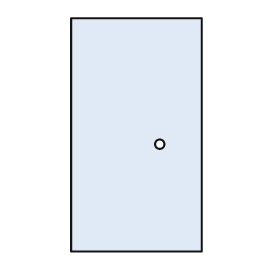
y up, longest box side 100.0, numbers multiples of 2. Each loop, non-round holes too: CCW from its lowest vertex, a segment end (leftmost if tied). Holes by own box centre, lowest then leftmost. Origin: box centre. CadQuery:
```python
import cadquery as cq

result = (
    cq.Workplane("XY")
    .moveTo(-28.0, -50.0)
    .lineTo(28.0, -50.0)
    .lineTo(28.0, 50.0)
    .lineTo(-28.0, 50.0)
    .close()
    .moveTo(10.0, -4.0)
    .circle(2.0)
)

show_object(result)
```